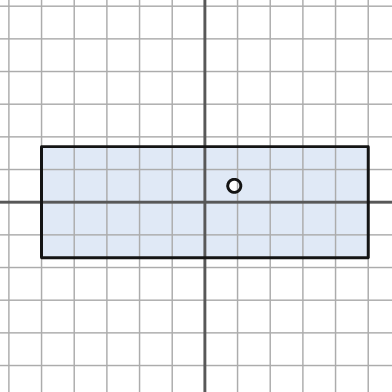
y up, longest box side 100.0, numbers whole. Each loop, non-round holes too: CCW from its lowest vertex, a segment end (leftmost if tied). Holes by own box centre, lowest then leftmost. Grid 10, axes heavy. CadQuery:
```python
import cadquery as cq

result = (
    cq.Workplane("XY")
    .moveTo(-50.0, -17.0)
    .lineTo(50.0, -17.0)
    .lineTo(50.0, 17.0)
    .lineTo(-50.0, 17.0)
    .close()
    .moveTo(9.0, 5.0)
    .circle(2.0)
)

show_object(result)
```